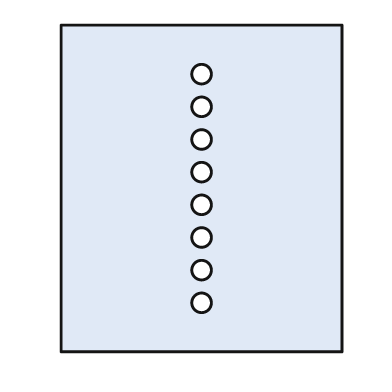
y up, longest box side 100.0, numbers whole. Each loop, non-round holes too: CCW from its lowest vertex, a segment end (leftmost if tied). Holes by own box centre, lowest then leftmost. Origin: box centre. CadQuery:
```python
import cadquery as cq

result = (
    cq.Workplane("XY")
    .moveTo(-43.0, -50.0)
    .lineTo(43.0, -50.0)
    .lineTo(43.0, 50.0)
    .lineTo(-43.0, 50.0)
    .close()
    .moveTo(0.0, -35.0)
    .circle(3.0)
    .moveTo(0.0, -25.0)
    .circle(3.0)
    .moveTo(0.0, -15.0)
    .circle(3.0)
    .moveTo(0.0, -5.0)
    .circle(3.0)
    .moveTo(0.0, 5.0)
    .circle(3.0)
    .moveTo(0.0, 15.0)
    .circle(3.0)
    .moveTo(0.0, 25.0)
    .circle(3.0)
    .moveTo(0.0, 35.0)
    .circle(3.0)
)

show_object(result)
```